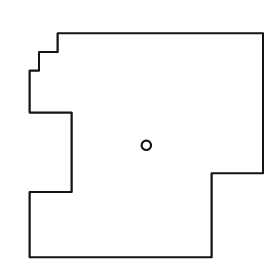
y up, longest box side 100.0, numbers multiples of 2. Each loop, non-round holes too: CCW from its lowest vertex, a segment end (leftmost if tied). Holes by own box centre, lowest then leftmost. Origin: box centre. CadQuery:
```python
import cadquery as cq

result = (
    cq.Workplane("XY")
    .moveTo(-50.0, -48.0)
    .lineTo(28.0, -48.0)
    .lineTo(28.0, -12.0)
    .lineTo(50.0, -12.0)
    .lineTo(50.0, 48.0)
    .lineTo(-38.0, 48.0)
    .lineTo(-38.0, 40.0)
    .lineTo(-46.0, 40.0)
    .lineTo(-46.0, 32.0)
    .lineTo(-50.0, 32.0)
    .lineTo(-50.0, 14.0)
    .lineTo(-32.0, 14.0)
    .lineTo(-32.0, -20.0)
    .lineTo(-50.0, -20.0)
    .close()
    .moveTo(0.0, 0.0)
    .circle(2.0)
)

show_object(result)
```